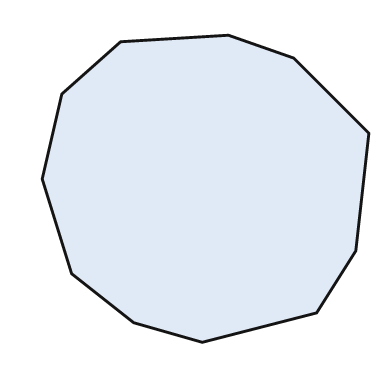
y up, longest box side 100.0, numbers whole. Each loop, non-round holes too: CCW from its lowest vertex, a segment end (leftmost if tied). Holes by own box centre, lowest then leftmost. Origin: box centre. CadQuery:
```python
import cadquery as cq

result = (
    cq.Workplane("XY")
    .moveTo(-1.0, -47.0)
    .lineTo(34.0, -38.0)
    .lineTo(46.0, -19.0)
    .lineTo(50.0, 17.0)
    .lineTo(27.0, 40.0)
    .lineTo(7.0, 47.0)
    .lineTo(-26.0, 45.0)
    .lineTo(-44.0, 29.0)
    .lineTo(-50.0, 3.0)
    .lineTo(-41.0, -26.0)
    .lineTo(-22.0, -41.0)
    .close()
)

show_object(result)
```